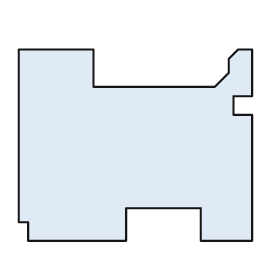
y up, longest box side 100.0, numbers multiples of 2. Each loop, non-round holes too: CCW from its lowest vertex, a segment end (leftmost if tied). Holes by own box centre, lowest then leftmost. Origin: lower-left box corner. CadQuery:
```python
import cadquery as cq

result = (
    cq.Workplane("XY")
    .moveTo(4.0, 0.0)
    .lineTo(46.0, 0.0)
    .lineTo(46.0, 14.0)
    .lineTo(78.0, 14.0)
    .lineTo(78.0, 0.0)
    .lineTo(100.0, 0.0)
    .lineTo(100.0, 54.0)
    .lineTo(92.0, 54.0)
    .lineTo(92.0, 62.0)
    .lineTo(100.0, 62.0)
    .lineTo(100.0, 82.0)
    .lineTo(94.0, 82.0)
    .lineTo(90.0, 78.0)
    .lineTo(90.0, 72.0)
    .lineTo(84.0, 66.0)
    .lineTo(32.0, 66.0)
    .lineTo(32.0, 82.0)
    .lineTo(0.0, 82.0)
    .lineTo(0.0, 8.0)
    .lineTo(4.0, 8.0)
    .close()
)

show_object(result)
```